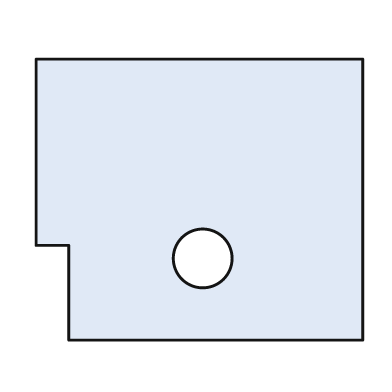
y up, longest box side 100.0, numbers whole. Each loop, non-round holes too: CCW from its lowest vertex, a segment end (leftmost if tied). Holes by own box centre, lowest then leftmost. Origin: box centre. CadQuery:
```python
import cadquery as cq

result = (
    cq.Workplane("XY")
    .moveTo(-40.0, -43.0)
    .lineTo(50.0, -43.0)
    .lineTo(50.0, 43.0)
    .lineTo(-50.0, 43.0)
    .lineTo(-50.0, -14.0)
    .lineTo(-40.0, -14.0)
    .close()
    .moveTo(1.0, -18.0)
    .circle(9.0)
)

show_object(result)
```